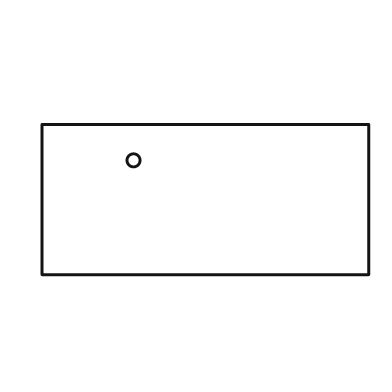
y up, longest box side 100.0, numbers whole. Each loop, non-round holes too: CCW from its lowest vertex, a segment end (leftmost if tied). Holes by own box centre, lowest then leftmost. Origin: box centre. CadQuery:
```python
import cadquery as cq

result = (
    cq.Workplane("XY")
    .moveTo(-50.0, -23.0)
    .lineTo(50.0, -23.0)
    .lineTo(50.0, 23.0)
    .lineTo(-50.0, 23.0)
    .close()
    .moveTo(-22.0, 12.0)
    .circle(2.0)
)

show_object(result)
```